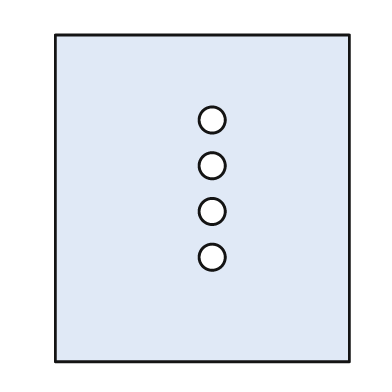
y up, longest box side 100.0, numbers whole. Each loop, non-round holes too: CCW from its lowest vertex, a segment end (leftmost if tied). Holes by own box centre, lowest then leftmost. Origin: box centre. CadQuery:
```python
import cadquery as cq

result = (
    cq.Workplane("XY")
    .moveTo(-45.0, -50.0)
    .lineTo(45.0, -50.0)
    .lineTo(45.0, 50.0)
    .lineTo(-45.0, 50.0)
    .close()
    .moveTo(3.0, -18.0)
    .circle(4.0)
    .moveTo(3.0, -4.0)
    .circle(4.0)
    .moveTo(3.0, 10.0)
    .circle(4.0)
    .moveTo(3.0, 24.0)
    .circle(4.0)
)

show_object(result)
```